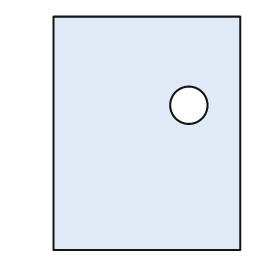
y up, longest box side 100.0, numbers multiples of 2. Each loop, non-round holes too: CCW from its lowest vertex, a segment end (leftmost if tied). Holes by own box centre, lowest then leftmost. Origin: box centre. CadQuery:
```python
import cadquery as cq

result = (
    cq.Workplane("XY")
    .moveTo(-40.0, -50.0)
    .lineTo(40.0, -50.0)
    .lineTo(40.0, 50.0)
    .lineTo(-40.0, 50.0)
    .close()
    .moveTo(18.0, 12.0)
    .circle(8.0)
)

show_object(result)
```